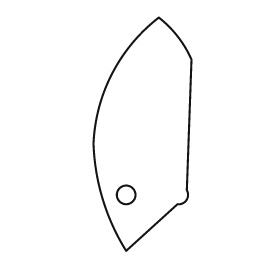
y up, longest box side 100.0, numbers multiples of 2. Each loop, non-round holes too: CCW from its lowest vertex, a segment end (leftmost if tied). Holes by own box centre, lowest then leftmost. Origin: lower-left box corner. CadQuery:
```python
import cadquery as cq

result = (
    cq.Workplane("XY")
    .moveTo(14.0, 0.0)
    .lineTo(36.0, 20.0)
    .threePointArc((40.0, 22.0), (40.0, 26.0))
    .lineTo(42.0, 82.0)
    .threePointArc((36.0, 92.0), (28.0, 100.0))
    .threePointArc((8.0, 76.0), (0.0, 46.0))
    .threePointArc((4.0, 22.0), (14.0, 0.0))
    .close()
    .moveTo(14.0, 24.0)
    .circle(4.0)
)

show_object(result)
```